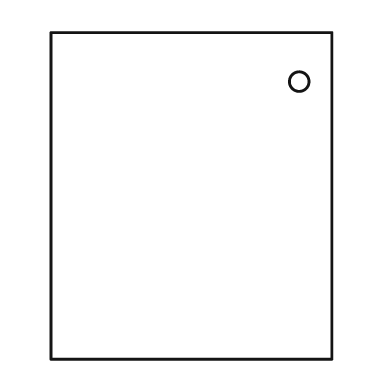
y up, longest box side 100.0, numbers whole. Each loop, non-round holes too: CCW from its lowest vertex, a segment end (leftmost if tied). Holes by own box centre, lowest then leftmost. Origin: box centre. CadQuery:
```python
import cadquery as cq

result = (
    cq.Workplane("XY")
    .moveTo(-43.0, -50.0)
    .lineTo(43.0, -50.0)
    .lineTo(43.0, 50.0)
    .lineTo(-43.0, 50.0)
    .close()
    .moveTo(33.0, 35.0)
    .circle(3.0)
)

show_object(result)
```